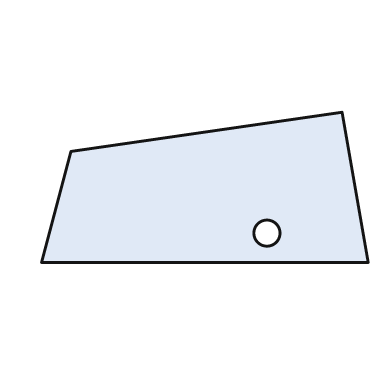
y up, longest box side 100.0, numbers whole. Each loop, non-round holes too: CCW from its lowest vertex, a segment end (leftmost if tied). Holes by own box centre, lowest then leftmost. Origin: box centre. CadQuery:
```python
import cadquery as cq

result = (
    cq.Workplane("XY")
    .moveTo(-50.0, -23.0)
    .lineTo(50.0, -23.0)
    .lineTo(42.0, 23.0)
    .lineTo(-41.0, 11.0)
    .close()
    .moveTo(19.0, -14.0)
    .circle(4.0)
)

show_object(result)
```